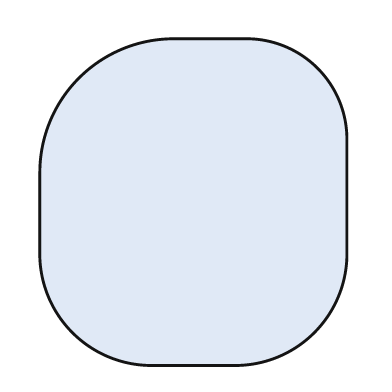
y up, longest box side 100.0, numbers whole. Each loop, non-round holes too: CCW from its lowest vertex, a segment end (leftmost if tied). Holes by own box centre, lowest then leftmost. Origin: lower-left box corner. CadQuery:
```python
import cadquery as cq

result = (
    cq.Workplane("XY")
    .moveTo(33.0, 0.0)
    .lineTo(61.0, 0.0)
    .threePointArc((84.0, 10.0), (94.0, 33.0))
    .lineTo(94.0, 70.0)
    .threePointArc((85.0, 91.0), (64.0, 100.0))
    .lineTo(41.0, 100.0)
    .threePointArc((12.0, 88.0), (0.0, 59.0))
    .lineTo(0.0, 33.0)
    .threePointArc((10.0, 10.0), (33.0, 0.0))
    .close()
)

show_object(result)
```